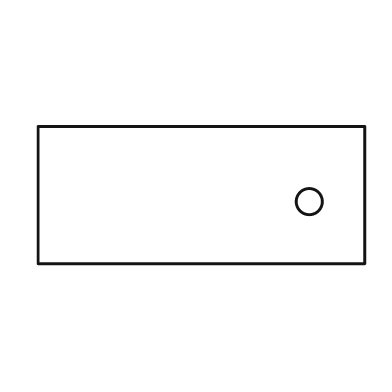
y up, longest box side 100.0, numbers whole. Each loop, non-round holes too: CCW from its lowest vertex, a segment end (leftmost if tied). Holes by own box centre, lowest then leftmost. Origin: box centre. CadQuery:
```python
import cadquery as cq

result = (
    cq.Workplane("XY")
    .moveTo(-50.0, -21.0)
    .lineTo(50.0, -21.0)
    .lineTo(50.0, 21.0)
    .lineTo(-50.0, 21.0)
    .close()
    .moveTo(33.0, -2.0)
    .circle(4.0)
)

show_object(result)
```